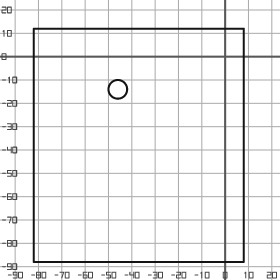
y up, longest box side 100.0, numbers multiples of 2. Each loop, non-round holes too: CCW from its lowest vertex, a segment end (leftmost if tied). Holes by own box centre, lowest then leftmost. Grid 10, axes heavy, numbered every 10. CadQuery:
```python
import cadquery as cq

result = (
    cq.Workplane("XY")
    .moveTo(-82.0, -88.0)
    .lineTo(8.0, -88.0)
    .lineTo(8.0, 12.0)
    .lineTo(-82.0, 12.0)
    .close()
    .moveTo(-46.0, -14.0)
    .circle(4.0)
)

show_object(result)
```